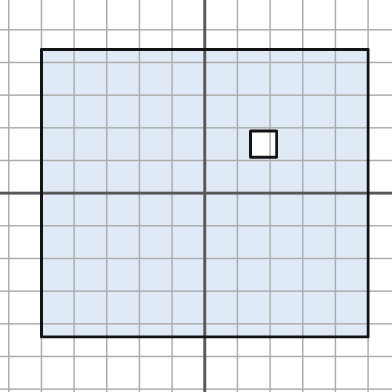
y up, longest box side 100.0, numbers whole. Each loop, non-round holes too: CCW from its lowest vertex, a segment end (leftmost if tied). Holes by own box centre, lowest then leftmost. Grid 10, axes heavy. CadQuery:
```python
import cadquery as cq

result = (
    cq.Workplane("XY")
    .moveTo(-50.0, -44.0)
    .lineTo(50.0, -44.0)
    .lineTo(50.0, 44.0)
    .lineTo(-50.0, 44.0)
    .close()
    .moveTo(14.0, 11.0)
    .lineTo(22.0, 11.0)
    .lineTo(22.0, 19.0)
    .lineTo(14.0, 19.0)
    .close()
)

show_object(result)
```